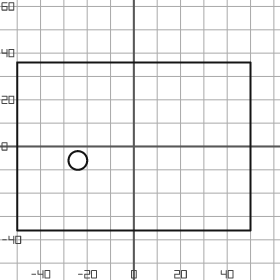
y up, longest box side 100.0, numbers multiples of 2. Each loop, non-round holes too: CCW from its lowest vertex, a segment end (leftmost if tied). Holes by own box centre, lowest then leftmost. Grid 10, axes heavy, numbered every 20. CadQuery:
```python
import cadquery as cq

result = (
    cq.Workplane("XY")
    .moveTo(-50.0, -36.0)
    .lineTo(50.0, -36.0)
    .lineTo(50.0, 36.0)
    .lineTo(-50.0, 36.0)
    .close()
    .moveTo(-24.0, -6.0)
    .circle(4.0)
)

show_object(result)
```